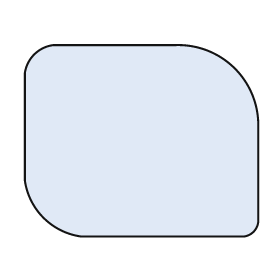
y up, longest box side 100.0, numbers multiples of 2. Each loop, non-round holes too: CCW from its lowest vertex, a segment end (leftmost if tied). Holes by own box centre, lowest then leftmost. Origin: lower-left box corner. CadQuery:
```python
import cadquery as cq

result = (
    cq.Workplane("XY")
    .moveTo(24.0, 0.0)
    .lineTo(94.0, 0.0)
    .threePointArc((98.0, 2.0), (100.0, 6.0))
    .lineTo(100.0, 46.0)
    .threePointArc((90.0, 72.0), (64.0, 82.0))
    .lineTo(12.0, 82.0)
    .threePointArc((4.0, 78.0), (0.0, 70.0))
    .lineTo(0.0, 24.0)
    .threePointArc((8.0, 8.0), (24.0, 0.0))
    .close()
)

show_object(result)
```